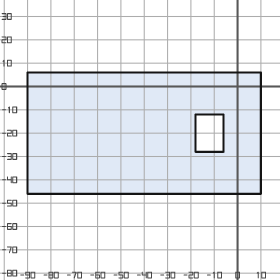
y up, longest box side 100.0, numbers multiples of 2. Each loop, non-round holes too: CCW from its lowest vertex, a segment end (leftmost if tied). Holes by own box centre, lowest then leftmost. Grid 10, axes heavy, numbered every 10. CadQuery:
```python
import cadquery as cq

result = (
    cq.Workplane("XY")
    .moveTo(-90.0, -46.0)
    .lineTo(10.0, -46.0)
    .lineTo(10.0, 6.0)
    .lineTo(-90.0, 6.0)
    .close()
    .moveTo(-18.0, -28.0)
    .lineTo(-6.0, -28.0)
    .lineTo(-6.0, -12.0)
    .lineTo(-18.0, -12.0)
    .close()
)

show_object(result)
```